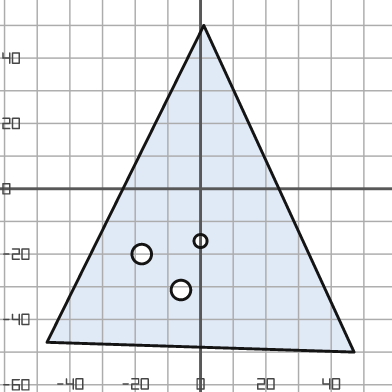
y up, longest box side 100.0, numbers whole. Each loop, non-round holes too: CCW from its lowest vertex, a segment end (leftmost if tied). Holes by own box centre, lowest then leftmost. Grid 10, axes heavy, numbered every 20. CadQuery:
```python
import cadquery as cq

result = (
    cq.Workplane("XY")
    .moveTo(47.0, -50.0)
    .lineTo(1.0, 50.0)
    .lineTo(-47.0, -47.0)
    .close()
    .moveTo(-6.0, -31.0)
    .circle(3.0)
    .moveTo(-18.0, -20.0)
    .circle(3.0)
    .moveTo(0.0, -16.0)
    .circle(2.0)
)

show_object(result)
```